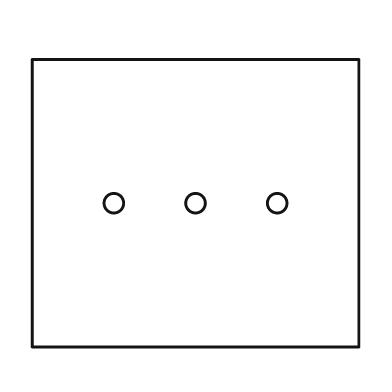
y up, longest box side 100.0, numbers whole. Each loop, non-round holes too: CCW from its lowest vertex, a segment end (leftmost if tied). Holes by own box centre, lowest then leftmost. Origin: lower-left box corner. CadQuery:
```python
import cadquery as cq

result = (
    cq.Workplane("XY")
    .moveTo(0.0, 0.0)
    .lineTo(100.0, 0.0)
    .lineTo(100.0, 88.0)
    .lineTo(0.0, 88.0)
    .close()
    .moveTo(25.0, 44.0)
    .circle(3.0)
    .moveTo(50.0, 44.0)
    .circle(3.0)
    .moveTo(75.0, 44.0)
    .circle(3.0)
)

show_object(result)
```